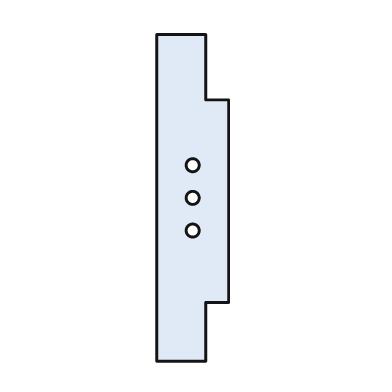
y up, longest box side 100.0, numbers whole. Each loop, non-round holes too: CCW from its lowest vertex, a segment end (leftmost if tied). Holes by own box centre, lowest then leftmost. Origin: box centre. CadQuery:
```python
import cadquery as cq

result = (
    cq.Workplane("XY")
    .moveTo(-11.0, -50.0)
    .lineTo(4.0, -50.0)
    .lineTo(4.0, -32.0)
    .lineTo(11.0, -32.0)
    .lineTo(11.0, 30.0)
    .lineTo(4.0, 30.0)
    .lineTo(4.0, 50.0)
    .lineTo(-11.0, 50.0)
    .close()
    .moveTo(0.0, -10.0)
    .circle(2.0)
    .moveTo(0.0, 0.0)
    .circle(2.0)
    .moveTo(0.0, 10.0)
    .circle(2.0)
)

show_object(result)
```